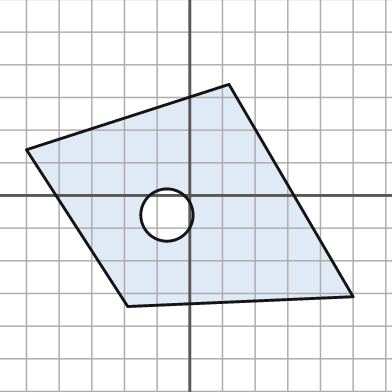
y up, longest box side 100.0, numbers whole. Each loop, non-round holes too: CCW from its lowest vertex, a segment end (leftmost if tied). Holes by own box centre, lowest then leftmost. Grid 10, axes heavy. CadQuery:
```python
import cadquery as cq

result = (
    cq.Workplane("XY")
    .moveTo(-19.0, -34.0)
    .lineTo(50.0, -31.0)
    .lineTo(12.0, 34.0)
    .lineTo(-50.0, 14.0)
    .close()
    .moveTo(-7.0, -6.0)
    .circle(8.0)
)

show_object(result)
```